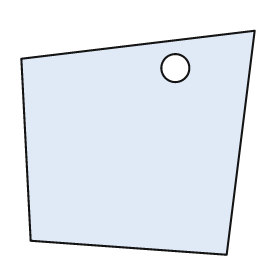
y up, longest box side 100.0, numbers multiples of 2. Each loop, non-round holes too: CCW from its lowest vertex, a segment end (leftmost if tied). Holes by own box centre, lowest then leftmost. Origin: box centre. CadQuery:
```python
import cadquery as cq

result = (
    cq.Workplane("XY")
    .moveTo(38.0, -48.0)
    .lineTo(50.0, 48.0)
    .lineTo(-50.0, 36.0)
    .lineTo(-46.0, -42.0)
    .close()
    .moveTo(16.0, 32.0)
    .circle(6.0)
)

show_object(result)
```